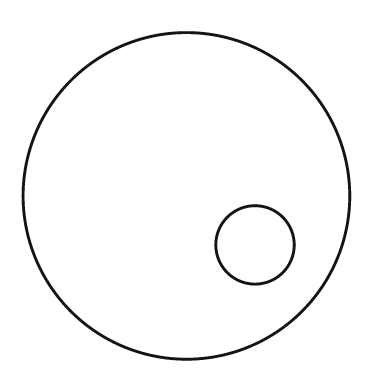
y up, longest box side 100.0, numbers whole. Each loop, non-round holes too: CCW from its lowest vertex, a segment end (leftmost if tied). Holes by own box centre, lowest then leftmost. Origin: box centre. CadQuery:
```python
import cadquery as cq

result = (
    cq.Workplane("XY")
    .moveTo(0.0, 0.0)
    .circle(50.0)
    .moveTo(21.0, -15.0)
    .circle(12.0)
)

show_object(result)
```